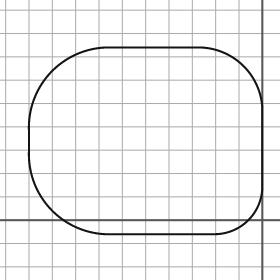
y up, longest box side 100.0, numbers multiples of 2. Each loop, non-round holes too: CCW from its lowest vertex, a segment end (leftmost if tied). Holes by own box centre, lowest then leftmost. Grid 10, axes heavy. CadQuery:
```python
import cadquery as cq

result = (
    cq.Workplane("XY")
    .moveTo(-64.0, -6.0)
    .lineTo(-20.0, -6.0)
    .threePointArc((-6.0, 0.0), (0.0, 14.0))
    .lineTo(0.0, 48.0)
    .threePointArc((-8.0, 66.0), (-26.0, 74.0))
    .lineTo(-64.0, 74.0)
    .threePointArc((-90.0, 64.0), (-100.0, 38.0))
    .lineTo(-100.0, 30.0)
    .threePointArc((-90.0, 4.0), (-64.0, -6.0))
    .close()
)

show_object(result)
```